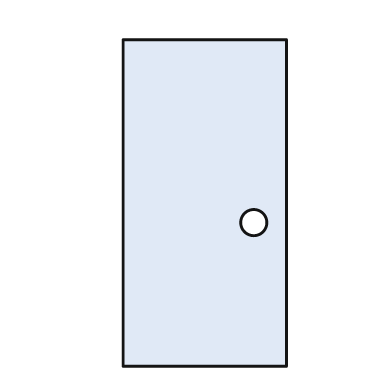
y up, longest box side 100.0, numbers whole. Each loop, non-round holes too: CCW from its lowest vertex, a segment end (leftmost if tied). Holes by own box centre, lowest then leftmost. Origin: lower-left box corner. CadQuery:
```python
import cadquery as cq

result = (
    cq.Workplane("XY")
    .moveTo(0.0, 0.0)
    .lineTo(50.0, 0.0)
    .lineTo(50.0, 100.0)
    .lineTo(0.0, 100.0)
    .close()
    .moveTo(40.0, 44.0)
    .circle(4.0)
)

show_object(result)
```